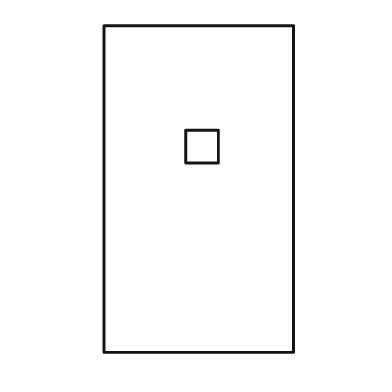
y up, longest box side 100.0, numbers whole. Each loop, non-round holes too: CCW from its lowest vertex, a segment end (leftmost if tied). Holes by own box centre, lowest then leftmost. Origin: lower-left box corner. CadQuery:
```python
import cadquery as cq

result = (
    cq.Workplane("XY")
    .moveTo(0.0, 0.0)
    .lineTo(58.0, 0.0)
    .lineTo(58.0, 100.0)
    .lineTo(0.0, 100.0)
    .close()
    .moveTo(25.0, 58.0)
    .lineTo(35.0, 58.0)
    .lineTo(35.0, 68.0)
    .lineTo(25.0, 68.0)
    .close()
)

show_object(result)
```